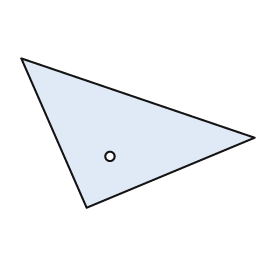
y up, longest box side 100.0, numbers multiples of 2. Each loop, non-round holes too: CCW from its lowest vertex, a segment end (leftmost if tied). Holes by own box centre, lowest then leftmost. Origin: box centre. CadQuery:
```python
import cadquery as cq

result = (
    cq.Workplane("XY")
    .moveTo(-22.0, -32.0)
    .lineTo(50.0, -2.0)
    .lineTo(-50.0, 32.0)
    .close()
    .moveTo(-12.0, -10.0)
    .circle(2.0)
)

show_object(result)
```